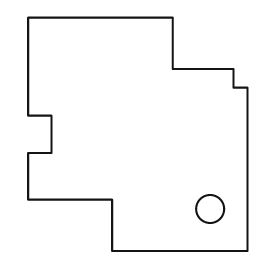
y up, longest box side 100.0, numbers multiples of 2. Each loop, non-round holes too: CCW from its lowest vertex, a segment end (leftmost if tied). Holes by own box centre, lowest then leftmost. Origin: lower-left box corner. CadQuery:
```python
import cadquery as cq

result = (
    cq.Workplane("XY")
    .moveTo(36.0, 0.0)
    .lineTo(94.0, 0.0)
    .lineTo(94.0, 70.0)
    .lineTo(88.0, 70.0)
    .lineTo(88.0, 78.0)
    .lineTo(62.0, 78.0)
    .lineTo(62.0, 100.0)
    .lineTo(0.0, 100.0)
    .lineTo(0.0, 58.0)
    .lineTo(10.0, 58.0)
    .lineTo(10.0, 42.0)
    .lineTo(0.0, 42.0)
    .lineTo(0.0, 22.0)
    .lineTo(36.0, 22.0)
    .close()
    .moveTo(78.0, 18.0)
    .circle(6.0)
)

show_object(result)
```